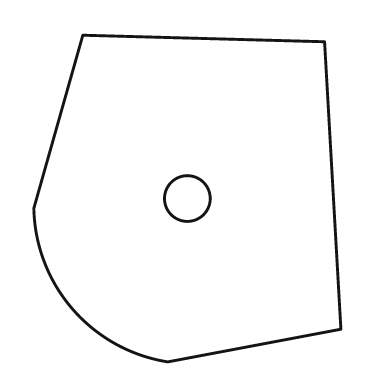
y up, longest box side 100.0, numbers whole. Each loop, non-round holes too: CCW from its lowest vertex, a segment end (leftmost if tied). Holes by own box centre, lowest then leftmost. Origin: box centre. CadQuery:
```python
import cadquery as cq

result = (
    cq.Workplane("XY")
    .moveTo(-6.0, -50.0)
    .lineTo(47.0, -40.0)
    .lineTo(42.0, 48.0)
    .lineTo(-32.0, 50.0)
    .lineTo(-47.0, -3.0)
    .threePointArc((-35.0, -34.0), (-6.0, -50.0))
    .close()
    .moveTo(0.0, 0.0)
    .circle(7.0)
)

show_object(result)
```